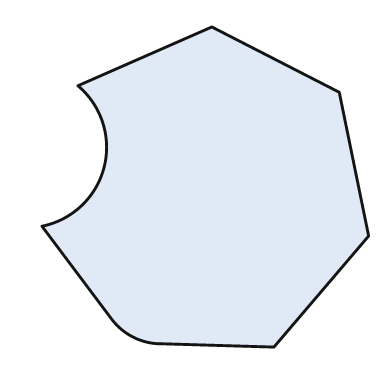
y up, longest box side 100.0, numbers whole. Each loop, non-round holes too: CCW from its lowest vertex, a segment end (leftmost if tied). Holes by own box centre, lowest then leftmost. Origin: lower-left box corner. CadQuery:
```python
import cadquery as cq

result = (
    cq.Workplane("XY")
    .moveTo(71.0, 0.0)
    .lineTo(100.0, 34.0)
    .lineTo(91.0, 78.0)
    .lineTo(52.0, 98.0)
    .lineTo(11.0, 80.0)
    .threePointArc((19.0, 55.0), (0.0, 37.0))
    .lineTo(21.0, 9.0)
    .threePointArc((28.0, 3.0), (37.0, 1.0))
    .close()
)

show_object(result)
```